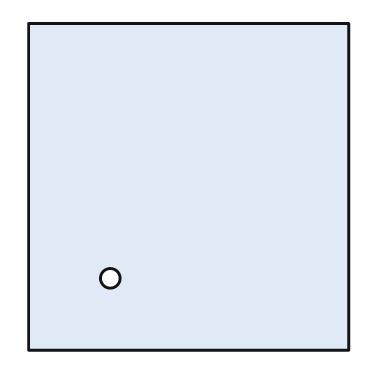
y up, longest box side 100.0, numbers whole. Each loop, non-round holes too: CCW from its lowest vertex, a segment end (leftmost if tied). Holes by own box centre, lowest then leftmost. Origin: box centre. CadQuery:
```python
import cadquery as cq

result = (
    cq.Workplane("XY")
    .moveTo(-49.0, -50.0)
    .lineTo(49.0, -50.0)
    .lineTo(49.0, 50.0)
    .lineTo(-49.0, 50.0)
    .close()
    .moveTo(-24.0, -28.0)
    .circle(3.0)
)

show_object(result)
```